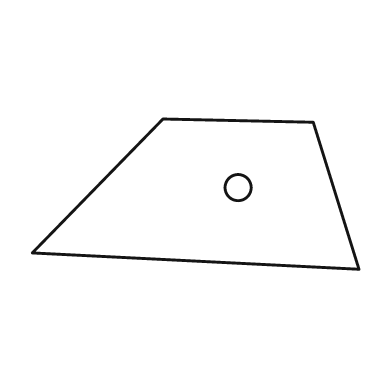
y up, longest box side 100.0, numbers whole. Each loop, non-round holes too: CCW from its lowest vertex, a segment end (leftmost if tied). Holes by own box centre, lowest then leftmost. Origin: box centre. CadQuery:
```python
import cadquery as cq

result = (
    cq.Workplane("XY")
    .moveTo(50.0, -23.0)
    .lineTo(36.0, 22.0)
    .lineTo(-10.0, 23.0)
    .lineTo(-50.0, -18.0)
    .close()
    .moveTo(13.0, 2.0)
    .circle(4.0)
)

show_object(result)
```